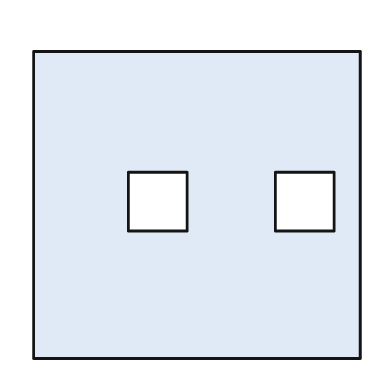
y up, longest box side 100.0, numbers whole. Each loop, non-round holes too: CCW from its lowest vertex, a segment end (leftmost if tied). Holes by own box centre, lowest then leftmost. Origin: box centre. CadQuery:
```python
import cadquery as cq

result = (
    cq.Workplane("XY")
    .moveTo(-50.0, -47.0)
    .lineTo(50.0, -47.0)
    .lineTo(50.0, 47.0)
    .lineTo(-50.0, 47.0)
    .close()
    .moveTo(-21.0, -8.0)
    .lineTo(-3.0, -8.0)
    .lineTo(-3.0, 10.0)
    .lineTo(-21.0, 10.0)
    .close()
    .moveTo(24.0, -8.0)
    .lineTo(42.0, -8.0)
    .lineTo(42.0, 10.0)
    .lineTo(24.0, 10.0)
    .close()
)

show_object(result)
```